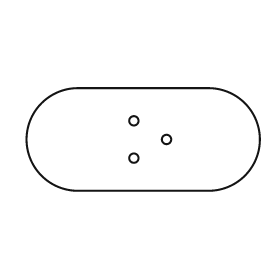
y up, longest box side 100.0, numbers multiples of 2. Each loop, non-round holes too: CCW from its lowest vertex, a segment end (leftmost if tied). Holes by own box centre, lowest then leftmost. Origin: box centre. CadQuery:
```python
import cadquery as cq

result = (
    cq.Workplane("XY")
    .moveTo(-28.0, -22.0)
    .lineTo(28.0, -22.0)
    .threePointArc((50.0, 0.0), (28.0, 22.0))
    .lineTo(-28.0, 22.0)
    .threePointArc((-50.0, 0.0), (-28.0, -22.0))
    .close()
    .moveTo(-4.0, -8.0)
    .circle(2.0)
    .moveTo(10.0, 0.0)
    .circle(2.0)
    .moveTo(-4.0, 8.0)
    .circle(2.0)
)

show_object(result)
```